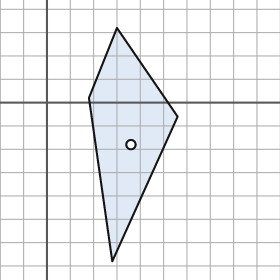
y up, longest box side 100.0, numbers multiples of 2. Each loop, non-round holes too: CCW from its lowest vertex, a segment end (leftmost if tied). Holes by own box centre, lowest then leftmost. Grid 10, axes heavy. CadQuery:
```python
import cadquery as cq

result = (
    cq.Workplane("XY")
    .moveTo(28.0, -68.0)
    .lineTo(56.0, -6.0)
    .lineTo(30.0, 32.0)
    .lineTo(18.0, 2.0)
    .close()
    .moveTo(36.0, -18.0)
    .circle(2.0)
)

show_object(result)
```